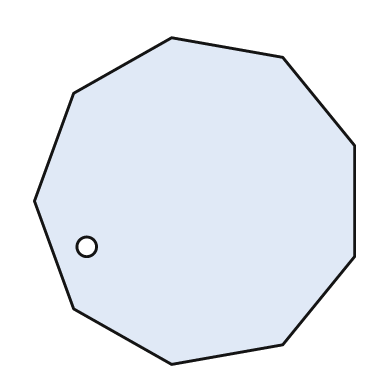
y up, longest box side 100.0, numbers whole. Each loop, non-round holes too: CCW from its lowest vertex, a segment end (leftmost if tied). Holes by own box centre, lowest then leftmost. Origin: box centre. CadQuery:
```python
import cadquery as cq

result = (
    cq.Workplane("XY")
    .moveTo(-7.0, -50.0)
    .lineTo(27.0, -44.0)
    .lineTo(49.0, -17.0)
    .lineTo(49.0, 17.0)
    .lineTo(27.0, 44.0)
    .lineTo(-7.0, 50.0)
    .lineTo(-37.0, 33.0)
    .lineTo(-49.0, 0.0)
    .lineTo(-37.0, -33.0)
    .close()
    .moveTo(-33.0, -14.0)
    .circle(3.0)
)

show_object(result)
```